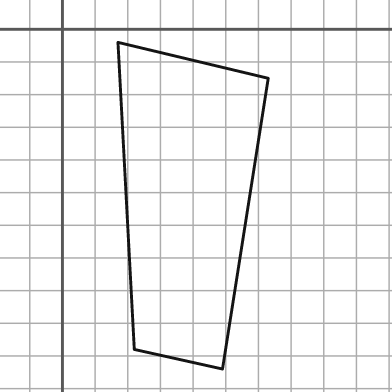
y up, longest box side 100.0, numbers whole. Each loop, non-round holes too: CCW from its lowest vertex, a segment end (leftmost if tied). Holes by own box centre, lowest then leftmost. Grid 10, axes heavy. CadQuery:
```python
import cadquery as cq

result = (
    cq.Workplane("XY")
    .moveTo(49.0, -104.0)
    .lineTo(63.0, -15.0)
    .lineTo(17.0, -4.0)
    .lineTo(22.0, -98.0)
    .close()
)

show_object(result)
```